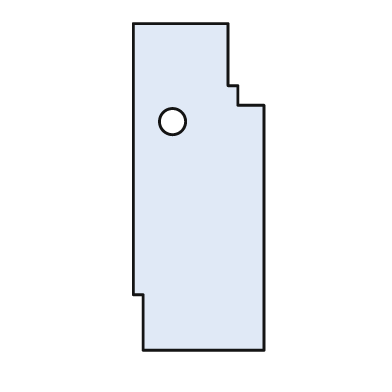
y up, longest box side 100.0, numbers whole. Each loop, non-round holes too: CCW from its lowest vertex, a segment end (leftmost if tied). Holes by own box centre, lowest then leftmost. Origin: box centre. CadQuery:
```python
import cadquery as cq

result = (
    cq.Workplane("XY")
    .moveTo(-17.0, -50.0)
    .lineTo(20.0, -50.0)
    .lineTo(20.0, 25.0)
    .lineTo(12.0, 25.0)
    .lineTo(12.0, 31.0)
    .lineTo(9.0, 31.0)
    .lineTo(9.0, 50.0)
    .lineTo(-20.0, 50.0)
    .lineTo(-20.0, -33.0)
    .lineTo(-17.0, -33.0)
    .close()
    .moveTo(-8.0, 20.0)
    .circle(4.0)
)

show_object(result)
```